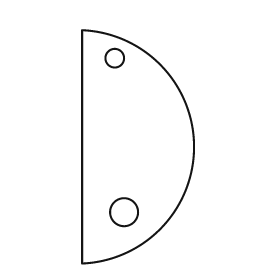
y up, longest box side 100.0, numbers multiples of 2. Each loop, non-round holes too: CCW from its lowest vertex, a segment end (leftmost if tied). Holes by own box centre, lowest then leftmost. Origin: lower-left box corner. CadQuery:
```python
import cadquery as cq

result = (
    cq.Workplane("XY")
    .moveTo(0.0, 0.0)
    .threePointArc((48.0, 50.0), (0.0, 100.0))
    .close()
    .moveTo(18.0, 22.0)
    .circle(6.0)
    .moveTo(14.0, 88.0)
    .circle(4.0)
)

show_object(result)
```